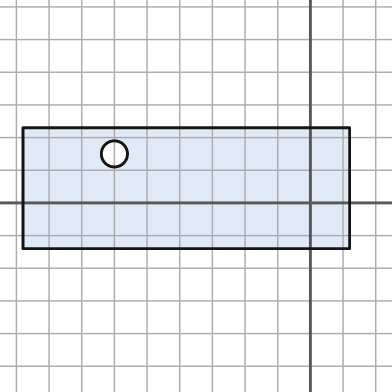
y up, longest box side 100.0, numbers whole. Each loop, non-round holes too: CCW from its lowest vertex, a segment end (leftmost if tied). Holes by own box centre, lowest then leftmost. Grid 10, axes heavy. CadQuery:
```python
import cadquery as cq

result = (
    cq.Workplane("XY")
    .moveTo(-88.0, -14.0)
    .lineTo(12.0, -14.0)
    .lineTo(12.0, 23.0)
    .lineTo(-88.0, 23.0)
    .close()
    .moveTo(-60.0, 15.0)
    .circle(4.0)
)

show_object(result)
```